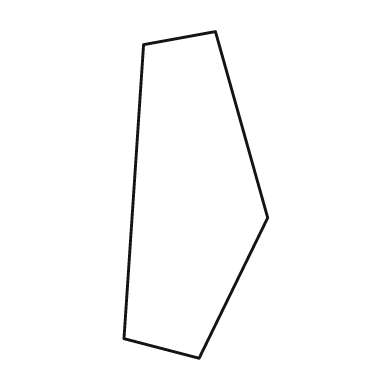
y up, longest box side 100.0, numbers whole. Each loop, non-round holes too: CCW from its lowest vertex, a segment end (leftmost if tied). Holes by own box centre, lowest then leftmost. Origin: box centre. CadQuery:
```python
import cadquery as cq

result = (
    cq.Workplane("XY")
    .moveTo(1.0, -50.0)
    .lineTo(22.0, -7.0)
    .lineTo(6.0, 50.0)
    .lineTo(-16.0, 46.0)
    .lineTo(-22.0, -44.0)
    .close()
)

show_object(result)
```